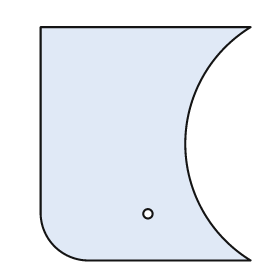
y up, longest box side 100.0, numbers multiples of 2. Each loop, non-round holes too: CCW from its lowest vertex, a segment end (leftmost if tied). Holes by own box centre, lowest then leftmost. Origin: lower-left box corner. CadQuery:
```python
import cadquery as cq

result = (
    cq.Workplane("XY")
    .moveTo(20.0, 0.0)
    .lineTo(90.0, 0.0)
    .threePointArc((62.0, 50.0), (90.0, 100.0))
    .lineTo(0.0, 100.0)
    .lineTo(0.0, 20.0)
    .threePointArc((6.0, 6.0), (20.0, 0.0))
    .close()
    .moveTo(46.0, 20.0)
    .circle(2.0)
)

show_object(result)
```